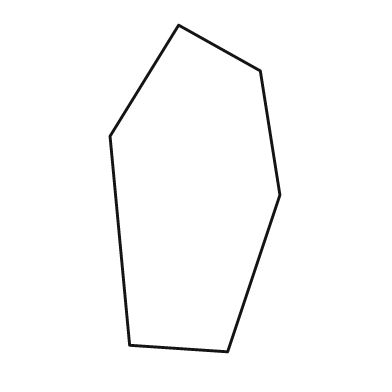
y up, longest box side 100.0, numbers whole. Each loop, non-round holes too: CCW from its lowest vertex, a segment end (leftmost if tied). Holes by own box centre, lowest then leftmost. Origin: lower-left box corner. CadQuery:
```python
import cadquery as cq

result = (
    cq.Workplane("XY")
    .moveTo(36.0, 0.0)
    .lineTo(52.0, 48.0)
    .lineTo(46.0, 86.0)
    .lineTo(21.0, 100.0)
    .lineTo(0.0, 66.0)
    .lineTo(6.0, 2.0)
    .close()
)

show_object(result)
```